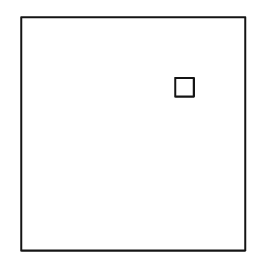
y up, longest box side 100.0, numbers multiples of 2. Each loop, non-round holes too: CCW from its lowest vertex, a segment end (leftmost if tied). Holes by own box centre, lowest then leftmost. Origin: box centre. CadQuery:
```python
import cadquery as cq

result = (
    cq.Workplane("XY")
    .moveTo(-48.0, -50.0)
    .lineTo(48.0, -50.0)
    .lineTo(48.0, 50.0)
    .lineTo(-48.0, 50.0)
    .close()
    .moveTo(18.0, 16.0)
    .lineTo(26.0, 16.0)
    .lineTo(26.0, 24.0)
    .lineTo(18.0, 24.0)
    .close()
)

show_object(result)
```